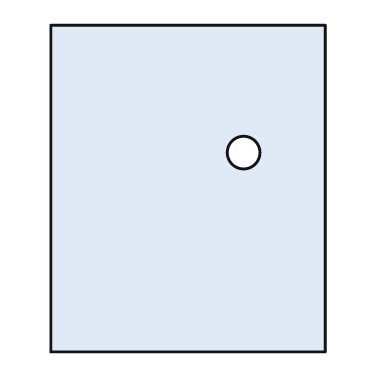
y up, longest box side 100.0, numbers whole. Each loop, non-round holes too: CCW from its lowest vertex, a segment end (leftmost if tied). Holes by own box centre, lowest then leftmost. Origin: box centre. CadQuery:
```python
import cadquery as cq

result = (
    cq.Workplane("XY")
    .moveTo(-42.0, -50.0)
    .lineTo(42.0, -50.0)
    .lineTo(42.0, 50.0)
    .lineTo(-42.0, 50.0)
    .close()
    .moveTo(17.0, 11.0)
    .circle(5.0)
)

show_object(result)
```